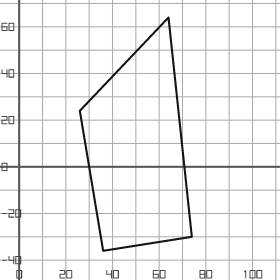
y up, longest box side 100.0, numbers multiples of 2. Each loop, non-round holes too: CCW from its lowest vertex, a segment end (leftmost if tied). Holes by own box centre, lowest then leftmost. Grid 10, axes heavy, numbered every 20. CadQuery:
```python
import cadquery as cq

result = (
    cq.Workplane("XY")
    .moveTo(36.0, -36.0)
    .lineTo(74.0, -30.0)
    .lineTo(64.0, 64.0)
    .lineTo(26.0, 24.0)
    .close()
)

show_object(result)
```